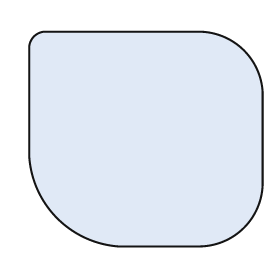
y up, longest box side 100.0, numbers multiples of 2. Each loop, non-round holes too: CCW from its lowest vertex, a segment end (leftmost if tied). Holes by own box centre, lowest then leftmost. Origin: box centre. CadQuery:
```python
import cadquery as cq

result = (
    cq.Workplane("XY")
    .moveTo(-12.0, -46.0)
    .lineTo(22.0, -46.0)
    .threePointArc((42.0, -38.0), (50.0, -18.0))
    .lineTo(50.0, 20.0)
    .threePointArc((42.0, 38.0), (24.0, 46.0))
    .lineTo(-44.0, 46.0)
    .threePointArc((-48.0, 44.0), (-50.0, 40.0))
    .lineTo(-50.0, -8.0)
    .threePointArc((-38.0, -34.0), (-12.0, -46.0))
    .close()
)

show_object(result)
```